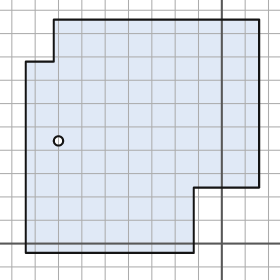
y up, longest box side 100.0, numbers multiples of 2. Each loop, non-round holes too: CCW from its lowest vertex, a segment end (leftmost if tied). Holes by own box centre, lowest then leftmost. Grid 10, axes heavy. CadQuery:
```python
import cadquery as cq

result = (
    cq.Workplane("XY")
    .moveTo(-84.0, -4.0)
    .lineTo(-12.0, -4.0)
    .lineTo(-12.0, 24.0)
    .lineTo(16.0, 24.0)
    .lineTo(16.0, 96.0)
    .lineTo(-72.0, 96.0)
    .lineTo(-72.0, 78.0)
    .lineTo(-84.0, 78.0)
    .close()
    .moveTo(-70.0, 44.0)
    .circle(2.0)
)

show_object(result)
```